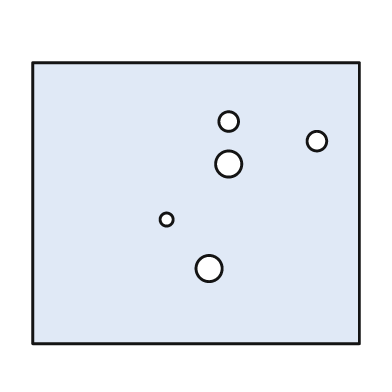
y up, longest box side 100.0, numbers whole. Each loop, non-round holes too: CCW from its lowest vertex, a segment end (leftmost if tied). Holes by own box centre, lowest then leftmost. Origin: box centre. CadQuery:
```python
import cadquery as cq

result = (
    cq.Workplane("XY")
    .moveTo(-50.0, -43.0)
    .lineTo(50.0, -43.0)
    .lineTo(50.0, 43.0)
    .lineTo(-50.0, 43.0)
    .close()
    .moveTo(4.0, -20.0)
    .circle(4.0)
    .moveTo(-9.0, -5.0)
    .circle(2.0)
    .moveTo(10.0, 12.0)
    .circle(4.0)
    .moveTo(37.0, 19.0)
    .circle(3.0)
    .moveTo(10.0, 25.0)
    .circle(3.0)
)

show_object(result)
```